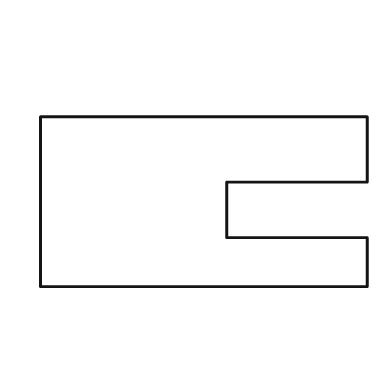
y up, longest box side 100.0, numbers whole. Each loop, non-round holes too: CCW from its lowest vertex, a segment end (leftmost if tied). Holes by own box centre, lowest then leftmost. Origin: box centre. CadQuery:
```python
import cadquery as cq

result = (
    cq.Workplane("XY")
    .moveTo(-50.0, -26.0)
    .lineTo(50.0, -26.0)
    .lineTo(50.0, -11.0)
    .lineTo(7.0, -11.0)
    .lineTo(7.0, 6.0)
    .lineTo(50.0, 6.0)
    .lineTo(50.0, 26.0)
    .lineTo(-50.0, 26.0)
    .close()
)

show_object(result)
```